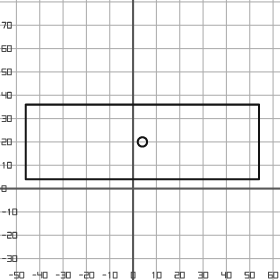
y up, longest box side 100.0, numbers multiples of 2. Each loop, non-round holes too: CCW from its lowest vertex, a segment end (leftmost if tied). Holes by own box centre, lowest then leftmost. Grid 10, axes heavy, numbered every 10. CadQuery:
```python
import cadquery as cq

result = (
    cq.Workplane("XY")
    .moveTo(-46.0, 4.0)
    .lineTo(54.0, 4.0)
    .lineTo(54.0, 36.0)
    .lineTo(-46.0, 36.0)
    .close()
    .moveTo(4.0, 20.0)
    .circle(2.0)
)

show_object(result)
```